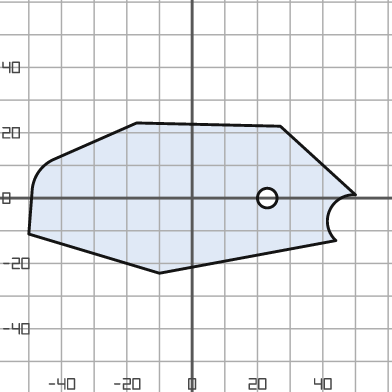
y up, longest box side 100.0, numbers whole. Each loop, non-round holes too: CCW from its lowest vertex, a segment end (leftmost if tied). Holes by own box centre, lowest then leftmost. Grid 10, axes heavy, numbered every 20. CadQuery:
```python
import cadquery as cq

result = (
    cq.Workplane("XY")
    .moveTo(-10.0, -23.0)
    .lineTo(44.0, -13.0)
    .threePointArc((42.0, -4.0), (50.0, 1.0))
    .lineTo(27.0, 22.0)
    .lineTo(-17.0, 23.0)
    .lineTo(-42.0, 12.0)
    .threePointArc((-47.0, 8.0), (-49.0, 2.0))
    .lineTo(-50.0, -11.0)
    .close()
    .moveTo(23.0, 0.0)
    .circle(3.0)
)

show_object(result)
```